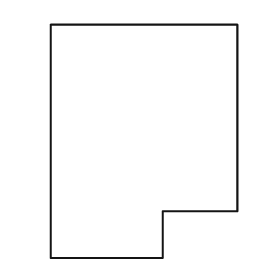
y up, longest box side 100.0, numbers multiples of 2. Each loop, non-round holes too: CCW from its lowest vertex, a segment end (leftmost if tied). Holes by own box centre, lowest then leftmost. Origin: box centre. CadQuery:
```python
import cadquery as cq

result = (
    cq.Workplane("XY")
    .moveTo(-40.0, -50.0)
    .lineTo(8.0, -50.0)
    .lineTo(8.0, -30.0)
    .lineTo(40.0, -30.0)
    .lineTo(40.0, 50.0)
    .lineTo(-40.0, 50.0)
    .close()
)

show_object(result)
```